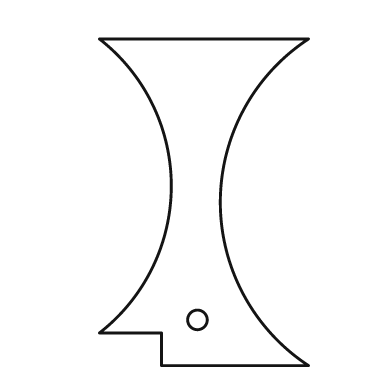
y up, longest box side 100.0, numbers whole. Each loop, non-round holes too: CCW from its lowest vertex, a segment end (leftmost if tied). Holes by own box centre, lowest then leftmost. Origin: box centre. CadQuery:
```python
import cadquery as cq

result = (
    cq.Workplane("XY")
    .moveTo(-13.0, -50.0)
    .lineTo(32.0, -50.0)
    .threePointArc((5.0, 0.0), (32.0, 50.0))
    .lineTo(-32.0, 50.0)
    .threePointArc((-10.0, 5.0), (-32.0, -40.0))
    .lineTo(-13.0, -40.0)
    .close()
    .moveTo(-2.0, -36.0)
    .circle(3.0)
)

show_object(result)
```